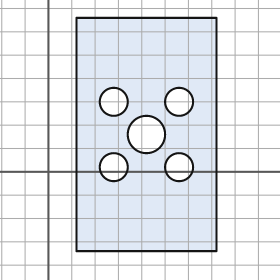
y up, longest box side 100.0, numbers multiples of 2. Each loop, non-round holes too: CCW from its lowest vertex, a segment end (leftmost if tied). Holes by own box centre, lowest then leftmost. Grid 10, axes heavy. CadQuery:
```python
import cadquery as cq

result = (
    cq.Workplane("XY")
    .moveTo(12.0, -34.0)
    .lineTo(72.0, -34.0)
    .lineTo(72.0, 66.0)
    .lineTo(12.0, 66.0)
    .close()
    .moveTo(28.0, 2.0)
    .circle(6.0)
    .moveTo(56.0, 2.0)
    .circle(6.0)
    .moveTo(42.0, 16.0)
    .circle(8.0)
    .moveTo(28.0, 30.0)
    .circle(6.0)
    .moveTo(56.0, 30.0)
    .circle(6.0)
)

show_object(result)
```